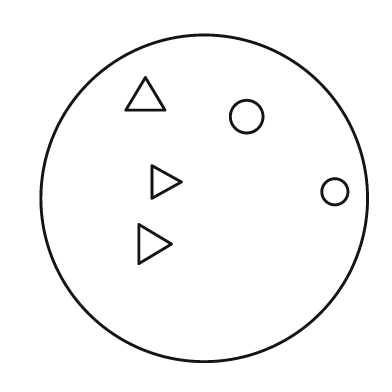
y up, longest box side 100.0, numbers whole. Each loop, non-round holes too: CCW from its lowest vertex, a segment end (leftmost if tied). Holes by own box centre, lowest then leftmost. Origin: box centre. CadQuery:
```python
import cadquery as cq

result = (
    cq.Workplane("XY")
    .moveTo(0.0, 0.0)
    .circle(50.0)
    .moveTo(-20.0, -20.0)
    .lineTo(-10.0, -14.0)
    .lineTo(-20.0, -8.0)
    .close()
    .moveTo(40.0, 2.0)
    .circle(4.0)
    .moveTo(-16.0, 0.0)
    .lineTo(-7.0, 5.0)
    .lineTo(-16.0, 10.0)
    .close()
    .moveTo(13.0, 25.0)
    .circle(5.0)
    .moveTo(-24.0, 27.0)
    .lineTo(-12.0, 27.0)
    .lineTo(-18.0, 37.0)
    .close()
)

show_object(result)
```